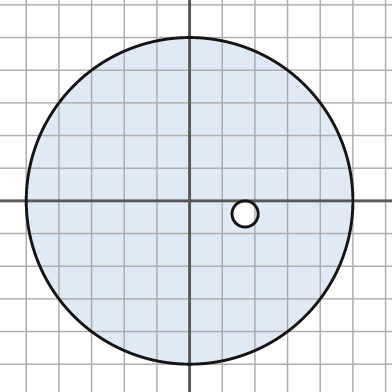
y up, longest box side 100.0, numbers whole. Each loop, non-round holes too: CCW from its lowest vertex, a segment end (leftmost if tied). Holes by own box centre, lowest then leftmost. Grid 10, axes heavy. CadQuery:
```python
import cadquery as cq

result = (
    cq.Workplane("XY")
    .moveTo(0.0, 0.0)
    .circle(50.0)
    .moveTo(17.0, -4.0)
    .circle(4.0)
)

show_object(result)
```